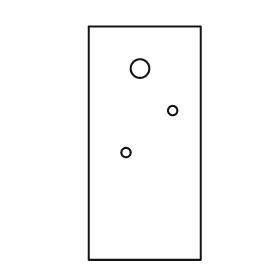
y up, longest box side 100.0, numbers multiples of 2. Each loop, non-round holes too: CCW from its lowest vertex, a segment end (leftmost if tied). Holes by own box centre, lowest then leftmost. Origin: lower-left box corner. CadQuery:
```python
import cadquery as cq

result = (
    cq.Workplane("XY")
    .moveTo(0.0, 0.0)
    .lineTo(48.0, 0.0)
    .lineTo(48.0, 100.0)
    .lineTo(0.0, 100.0)
    .close()
    .moveTo(16.0, 46.0)
    .circle(2.0)
    .moveTo(36.0, 64.0)
    .circle(2.0)
    .moveTo(22.0, 82.0)
    .circle(4.0)
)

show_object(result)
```